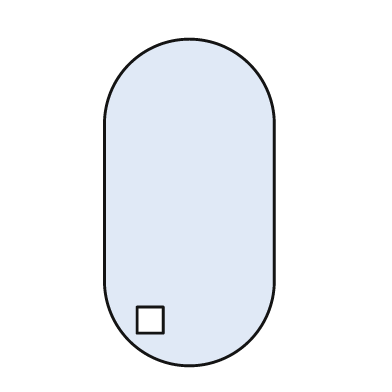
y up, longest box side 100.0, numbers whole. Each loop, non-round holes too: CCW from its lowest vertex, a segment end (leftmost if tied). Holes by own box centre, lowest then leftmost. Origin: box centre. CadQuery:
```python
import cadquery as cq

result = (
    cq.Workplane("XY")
    .moveTo(-26.0, -24.0)
    .threePointArc((0.0, -50.0), (26.0, -24.0))
    .lineTo(26.0, 24.0)
    .threePointArc((0.0, 50.0), (-26.0, 24.0))
    .close()
    .moveTo(-16.0, -40.0)
    .lineTo(-8.0, -40.0)
    .lineTo(-8.0, -32.0)
    .lineTo(-16.0, -32.0)
    .close()
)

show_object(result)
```